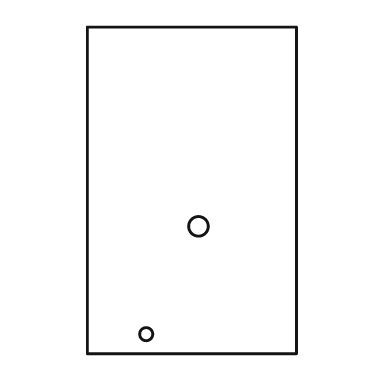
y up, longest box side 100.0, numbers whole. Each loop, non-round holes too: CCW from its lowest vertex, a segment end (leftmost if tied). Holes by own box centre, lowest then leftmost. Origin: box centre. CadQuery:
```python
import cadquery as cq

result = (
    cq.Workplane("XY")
    .moveTo(-32.0, -50.0)
    .lineTo(32.0, -50.0)
    .lineTo(32.0, 50.0)
    .lineTo(-32.0, 50.0)
    .close()
    .moveTo(-14.0, -44.0)
    .circle(2.0)
    .moveTo(2.0, -11.0)
    .circle(3.0)
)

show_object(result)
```